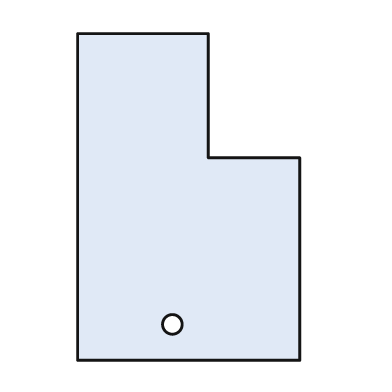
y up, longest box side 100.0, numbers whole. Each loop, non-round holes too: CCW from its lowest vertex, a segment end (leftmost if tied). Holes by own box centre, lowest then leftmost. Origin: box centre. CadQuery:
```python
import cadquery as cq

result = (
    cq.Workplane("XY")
    .moveTo(-34.0, -50.0)
    .lineTo(34.0, -50.0)
    .lineTo(34.0, 12.0)
    .lineTo(6.0, 12.0)
    .lineTo(6.0, 50.0)
    .lineTo(-34.0, 50.0)
    .close()
    .moveTo(-5.0, -39.0)
    .circle(3.0)
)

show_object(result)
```